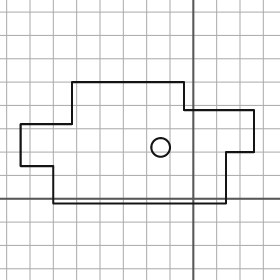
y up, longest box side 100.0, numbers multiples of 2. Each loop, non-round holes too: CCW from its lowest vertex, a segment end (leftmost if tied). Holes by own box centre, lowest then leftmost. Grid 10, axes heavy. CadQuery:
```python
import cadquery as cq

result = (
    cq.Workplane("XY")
    .moveTo(-60.0, -2.0)
    .lineTo(14.0, -2.0)
    .lineTo(14.0, 20.0)
    .lineTo(26.0, 20.0)
    .lineTo(26.0, 38.0)
    .lineTo(-4.0, 38.0)
    .lineTo(-4.0, 50.0)
    .lineTo(-52.0, 50.0)
    .lineTo(-52.0, 32.0)
    .lineTo(-74.0, 32.0)
    .lineTo(-74.0, 14.0)
    .lineTo(-60.0, 14.0)
    .close()
    .moveTo(-14.0, 22.0)
    .circle(4.0)
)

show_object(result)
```